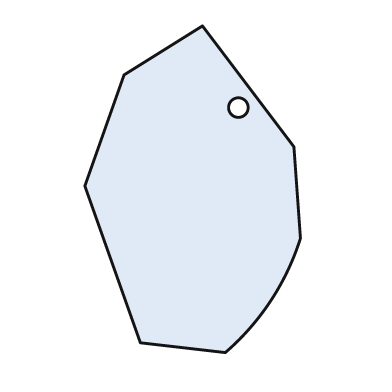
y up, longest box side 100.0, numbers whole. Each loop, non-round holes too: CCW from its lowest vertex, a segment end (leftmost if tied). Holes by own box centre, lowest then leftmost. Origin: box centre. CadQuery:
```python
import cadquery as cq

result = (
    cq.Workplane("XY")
    .moveTo(10.0, -50.0)
    .threePointArc((24.0, -34.0), (33.0, -15.0))
    .lineTo(31.0, 13.0)
    .lineTo(3.0, 50.0)
    .lineTo(-21.0, 35.0)
    .lineTo(-33.0, 1.0)
    .lineTo(-16.0, -47.0)
    .close()
    .moveTo(14.0, 25.0)
    .circle(3.0)
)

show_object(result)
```